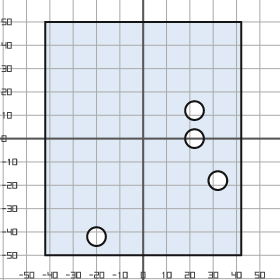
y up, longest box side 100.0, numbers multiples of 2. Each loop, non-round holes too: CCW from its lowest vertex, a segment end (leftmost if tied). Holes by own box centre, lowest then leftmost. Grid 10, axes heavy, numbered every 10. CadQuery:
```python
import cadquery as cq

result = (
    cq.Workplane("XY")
    .moveTo(-42.0, -50.0)
    .lineTo(42.0, -50.0)
    .lineTo(42.0, 50.0)
    .lineTo(-42.0, 50.0)
    .close()
    .moveTo(-20.0, -42.0)
    .circle(4.0)
    .moveTo(32.0, -18.0)
    .circle(4.0)
    .moveTo(22.0, 0.0)
    .circle(4.0)
    .moveTo(22.0, 12.0)
    .circle(4.0)
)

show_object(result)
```